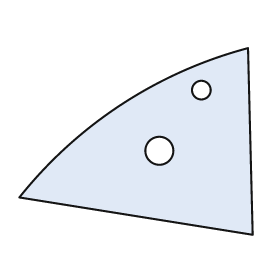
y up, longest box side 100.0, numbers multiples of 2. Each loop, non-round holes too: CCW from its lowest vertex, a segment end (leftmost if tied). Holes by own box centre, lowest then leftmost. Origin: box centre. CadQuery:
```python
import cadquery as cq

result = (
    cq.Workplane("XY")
    .moveTo(50.0, -40.0)
    .lineTo(48.0, 40.0)
    .threePointArc((-6.0, 16.0), (-50.0, -24.0))
    .close()
    .moveTo(10.0, -4.0)
    .circle(6.0)
    .moveTo(28.0, 22.0)
    .circle(4.0)
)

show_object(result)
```